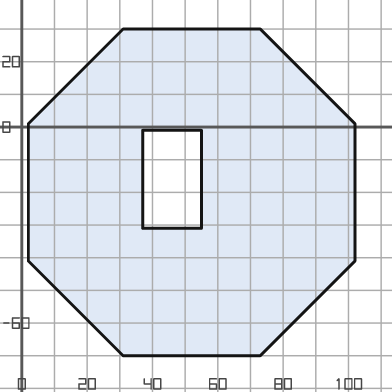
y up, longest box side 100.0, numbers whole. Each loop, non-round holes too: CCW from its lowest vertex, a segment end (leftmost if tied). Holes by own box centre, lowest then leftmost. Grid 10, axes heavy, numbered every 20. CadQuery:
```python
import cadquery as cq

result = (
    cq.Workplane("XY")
    .moveTo(31.0, -70.0)
    .lineTo(73.0, -70.0)
    .lineTo(102.0, -41.0)
    .lineTo(102.0, 1.0)
    .lineTo(73.0, 30.0)
    .lineTo(31.0, 30.0)
    .lineTo(2.0, 1.0)
    .lineTo(2.0, -41.0)
    .close()
    .moveTo(37.0, -31.0)
    .lineTo(55.0, -31.0)
    .lineTo(55.0, -1.0)
    .lineTo(37.0, -1.0)
    .close()
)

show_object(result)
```